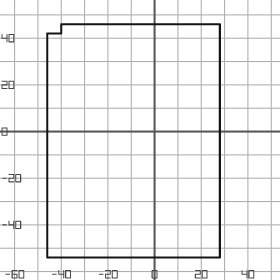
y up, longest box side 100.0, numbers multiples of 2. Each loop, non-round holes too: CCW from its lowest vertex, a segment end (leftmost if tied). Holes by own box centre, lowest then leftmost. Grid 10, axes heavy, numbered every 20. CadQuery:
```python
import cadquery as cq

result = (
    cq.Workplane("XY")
    .moveTo(-46.0, -54.0)
    .lineTo(28.0, -54.0)
    .lineTo(28.0, 46.0)
    .lineTo(-40.0, 46.0)
    .lineTo(-40.0, 42.0)
    .lineTo(-46.0, 42.0)
    .close()
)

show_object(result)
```